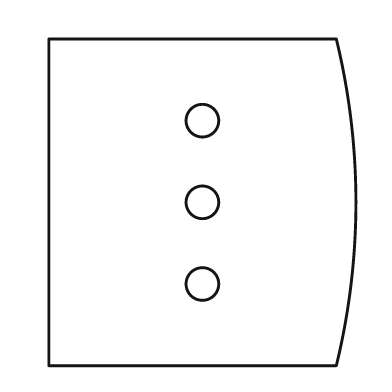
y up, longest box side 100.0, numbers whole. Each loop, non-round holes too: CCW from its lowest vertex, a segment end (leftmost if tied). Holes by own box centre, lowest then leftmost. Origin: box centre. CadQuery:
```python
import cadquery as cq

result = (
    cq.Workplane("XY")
    .moveTo(-47.0, -50.0)
    .lineTo(41.0, -50.0)
    .threePointArc((47.0, 0.0), (41.0, 50.0))
    .lineTo(-47.0, 50.0)
    .close()
    .moveTo(0.0, -25.0)
    .circle(5.0)
    .moveTo(0.0, 0.0)
    .circle(5.0)
    .moveTo(0.0, 25.0)
    .circle(5.0)
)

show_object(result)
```